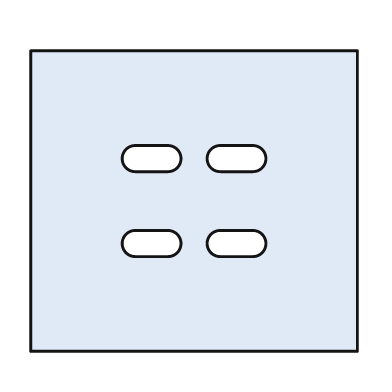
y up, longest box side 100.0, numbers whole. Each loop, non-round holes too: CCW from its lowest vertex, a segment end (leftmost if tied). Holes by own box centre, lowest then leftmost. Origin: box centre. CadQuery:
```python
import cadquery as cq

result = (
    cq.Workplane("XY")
    .moveTo(-50.0, -46.0)
    .lineTo(50.0, -46.0)
    .lineTo(50.0, 46.0)
    .lineTo(-50.0, 46.0)
    .close()
    .moveTo(-18.0, -17.0)
    .lineTo(-8.0, -17.0)
    .threePointArc((-4.0, -13.0), (-8.0, -9.0))
    .lineTo(-18.0, -9.0)
    .threePointArc((-22.0, -13.0), (-18.0, -17.0))
    .close()
    .moveTo(8.0, -17.0)
    .lineTo(18.0, -17.0)
    .threePointArc((22.0, -13.0), (18.0, -9.0))
    .lineTo(8.0, -9.0)
    .threePointArc((4.0, -13.0), (8.0, -17.0))
    .close()
    .moveTo(-18.0, 9.0)
    .lineTo(-8.0, 9.0)
    .threePointArc((-4.0, 13.0), (-8.0, 17.0))
    .lineTo(-18.0, 17.0)
    .threePointArc((-22.0, 13.0), (-18.0, 9.0))
    .close()
    .moveTo(8.0, 9.0)
    .lineTo(18.0, 9.0)
    .threePointArc((22.0, 13.0), (18.0, 17.0))
    .lineTo(8.0, 17.0)
    .threePointArc((4.0, 13.0), (8.0, 9.0))
    .close()
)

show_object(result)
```